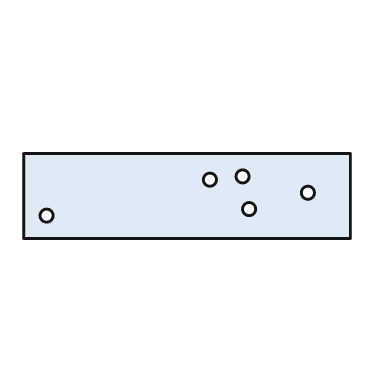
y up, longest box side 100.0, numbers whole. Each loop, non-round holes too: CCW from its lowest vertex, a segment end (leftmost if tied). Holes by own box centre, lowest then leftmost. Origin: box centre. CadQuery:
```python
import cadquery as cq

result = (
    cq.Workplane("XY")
    .moveTo(-50.0, -13.0)
    .lineTo(50.0, -13.0)
    .lineTo(50.0, 13.0)
    .lineTo(-50.0, 13.0)
    .close()
    .moveTo(-43.0, -6.0)
    .circle(2.0)
    .moveTo(19.0, -4.0)
    .circle(2.0)
    .moveTo(37.0, 1.0)
    .circle(2.0)
    .moveTo(7.0, 5.0)
    .circle(2.0)
    .moveTo(17.0, 6.0)
    .circle(2.0)
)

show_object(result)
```